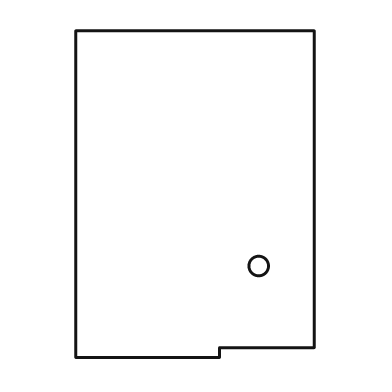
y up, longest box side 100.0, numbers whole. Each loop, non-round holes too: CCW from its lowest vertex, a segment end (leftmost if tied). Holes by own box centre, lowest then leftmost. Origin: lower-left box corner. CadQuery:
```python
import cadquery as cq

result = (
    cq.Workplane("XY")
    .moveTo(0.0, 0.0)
    .lineTo(44.0, 0.0)
    .lineTo(44.0, 3.0)
    .lineTo(73.0, 3.0)
    .lineTo(73.0, 100.0)
    .lineTo(0.0, 100.0)
    .close()
    .moveTo(56.0, 28.0)
    .circle(3.0)
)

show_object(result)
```